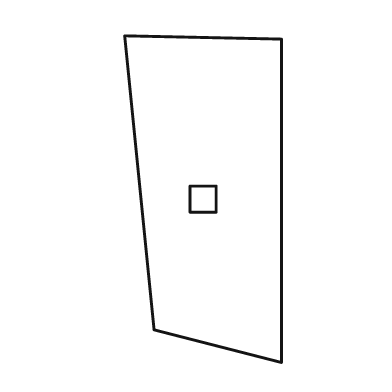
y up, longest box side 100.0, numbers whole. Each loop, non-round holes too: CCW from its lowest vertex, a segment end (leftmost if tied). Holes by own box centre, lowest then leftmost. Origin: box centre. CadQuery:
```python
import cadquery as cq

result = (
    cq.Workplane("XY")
    .moveTo(24.0, -50.0)
    .lineTo(24.0, 49.0)
    .lineTo(-24.0, 50.0)
    .lineTo(-15.0, -40.0)
    .close()
    .moveTo(-4.0, -4.0)
    .lineTo(4.0, -4.0)
    .lineTo(4.0, 4.0)
    .lineTo(-4.0, 4.0)
    .close()
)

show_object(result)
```